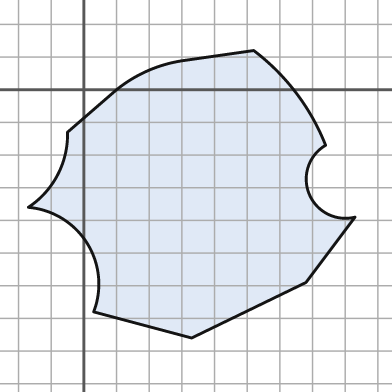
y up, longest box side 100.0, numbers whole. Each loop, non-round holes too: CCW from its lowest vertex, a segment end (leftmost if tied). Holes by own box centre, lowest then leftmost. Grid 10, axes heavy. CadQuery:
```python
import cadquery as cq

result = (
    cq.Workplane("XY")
    .moveTo(33.0, -76.0)
    .lineTo(68.0, -59.0)
    .lineTo(83.0, -39.0)
    .threePointArc((69.0, -32.0), (74.0, -17.0))
    .threePointArc((65.0, -1.0), (52.0, 12.0))
    .lineTo(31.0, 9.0)
    .threePointArc((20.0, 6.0), (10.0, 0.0))
    .lineTo(-5.0, -13.0)
    .threePointArc((-8.0, -26.0), (-17.0, -36.0))
    .threePointArc((1.0, -47.0), (3.0, -68.0))
    .close()
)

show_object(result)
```